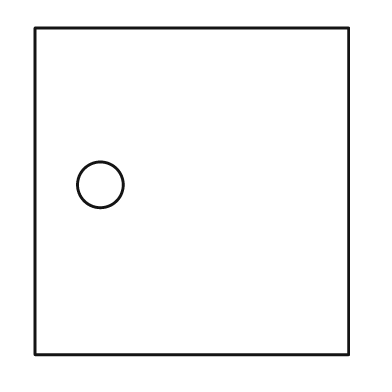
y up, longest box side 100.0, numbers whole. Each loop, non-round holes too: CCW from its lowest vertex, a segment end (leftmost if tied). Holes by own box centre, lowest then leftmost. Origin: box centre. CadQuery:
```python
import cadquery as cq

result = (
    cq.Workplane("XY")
    .moveTo(-48.0, -50.0)
    .lineTo(48.0, -50.0)
    .lineTo(48.0, 50.0)
    .lineTo(-48.0, 50.0)
    .close()
    .moveTo(-28.0, 2.0)
    .circle(7.0)
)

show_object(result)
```